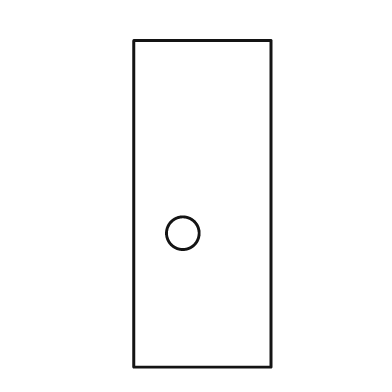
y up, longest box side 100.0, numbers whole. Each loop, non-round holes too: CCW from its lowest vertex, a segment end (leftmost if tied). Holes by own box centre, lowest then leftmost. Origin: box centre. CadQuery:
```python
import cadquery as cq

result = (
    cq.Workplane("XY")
    .moveTo(-21.0, -50.0)
    .lineTo(21.0, -50.0)
    .lineTo(21.0, 50.0)
    .lineTo(-21.0, 50.0)
    .close()
    .moveTo(-6.0, -9.0)
    .circle(5.0)
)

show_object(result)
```